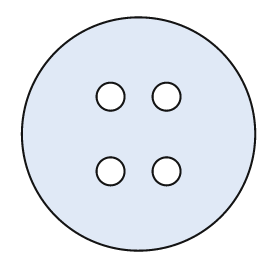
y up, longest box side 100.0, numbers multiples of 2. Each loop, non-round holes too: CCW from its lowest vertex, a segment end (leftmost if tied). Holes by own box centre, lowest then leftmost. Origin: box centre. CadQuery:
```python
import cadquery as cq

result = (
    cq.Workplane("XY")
    .moveTo(0.0, 0.0)
    .circle(50.0)
    .moveTo(-12.0, -16.0)
    .circle(6.0)
    .moveTo(12.0, -16.0)
    .circle(6.0)
    .moveTo(-12.0, 16.0)
    .circle(6.0)
    .moveTo(12.0, 16.0)
    .circle(6.0)
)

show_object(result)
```